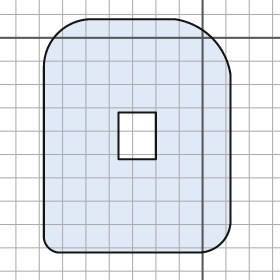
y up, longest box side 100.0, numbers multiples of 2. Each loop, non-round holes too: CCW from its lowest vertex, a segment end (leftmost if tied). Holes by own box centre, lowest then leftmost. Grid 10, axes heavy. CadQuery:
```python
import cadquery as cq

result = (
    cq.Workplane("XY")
    .moveTo(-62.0, -92.0)
    .lineTo(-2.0, -92.0)
    .threePointArc((8.0, -88.0), (12.0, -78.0))
    .lineTo(12.0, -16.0)
    .threePointArc((4.0, 0.0), (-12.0, 8.0))
    .lineTo(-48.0, 8.0)
    .threePointArc((-62.0, 2.0), (-68.0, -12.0))
    .lineTo(-68.0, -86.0)
    .threePointArc((-66.0, -90.0), (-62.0, -92.0))
    .close()
    .moveTo(-36.0, -52.0)
    .lineTo(-20.0, -52.0)
    .lineTo(-20.0, -32.0)
    .lineTo(-36.0, -32.0)
    .close()
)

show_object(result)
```